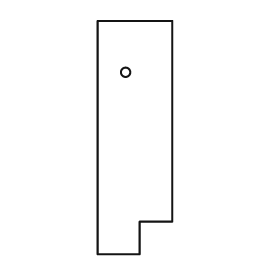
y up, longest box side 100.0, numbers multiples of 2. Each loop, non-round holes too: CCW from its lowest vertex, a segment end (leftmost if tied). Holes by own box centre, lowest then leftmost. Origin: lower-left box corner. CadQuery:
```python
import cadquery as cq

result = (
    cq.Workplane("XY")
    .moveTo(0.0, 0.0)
    .lineTo(18.0, 0.0)
    .lineTo(18.0, 14.0)
    .lineTo(32.0, 14.0)
    .lineTo(32.0, 100.0)
    .lineTo(0.0, 100.0)
    .close()
    .moveTo(12.0, 78.0)
    .circle(2.0)
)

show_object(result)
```